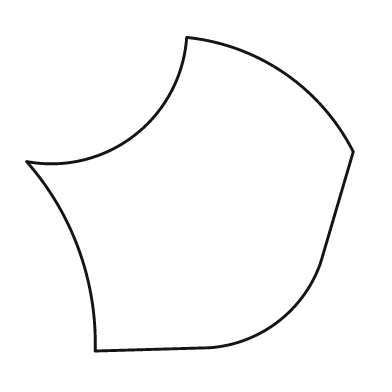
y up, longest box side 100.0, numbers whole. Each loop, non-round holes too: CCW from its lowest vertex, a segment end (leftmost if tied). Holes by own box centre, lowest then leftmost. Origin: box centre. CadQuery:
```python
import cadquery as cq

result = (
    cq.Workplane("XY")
    .moveTo(-29.0, -48.0)
    .lineTo(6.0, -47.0)
    .threePointArc((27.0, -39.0), (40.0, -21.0))
    .lineTo(50.0, 13.0)
    .threePointArc((29.0, 37.0), (-1.0, 48.0))
    .threePointArc((-17.0, 18.0), (-50.0, 10.0))
    .threePointArc((-34.0, -17.0), (-29.0, -48.0))
    .close()
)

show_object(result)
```